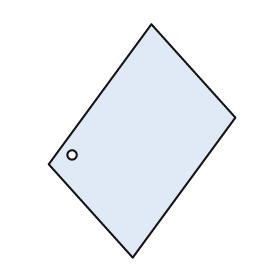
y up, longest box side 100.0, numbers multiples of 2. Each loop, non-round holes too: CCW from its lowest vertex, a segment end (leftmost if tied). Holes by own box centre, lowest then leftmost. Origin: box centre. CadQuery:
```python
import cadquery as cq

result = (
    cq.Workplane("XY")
    .moveTo(-4.0, -50.0)
    .lineTo(40.0, 10.0)
    .lineTo(4.0, 50.0)
    .lineTo(-40.0, -10.0)
    .close()
    .moveTo(-30.0, -6.0)
    .circle(2.0)
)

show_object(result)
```